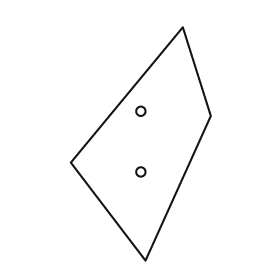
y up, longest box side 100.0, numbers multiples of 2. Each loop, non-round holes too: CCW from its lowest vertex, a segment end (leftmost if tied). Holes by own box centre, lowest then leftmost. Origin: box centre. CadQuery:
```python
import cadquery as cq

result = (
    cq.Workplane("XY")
    .moveTo(2.0, -50.0)
    .lineTo(30.0, 12.0)
    .lineTo(18.0, 50.0)
    .lineTo(-30.0, -8.0)
    .close()
    .moveTo(0.0, -12.0)
    .circle(2.0)
    .moveTo(0.0, 14.0)
    .circle(2.0)
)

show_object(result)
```